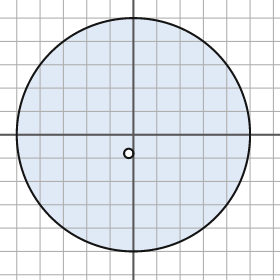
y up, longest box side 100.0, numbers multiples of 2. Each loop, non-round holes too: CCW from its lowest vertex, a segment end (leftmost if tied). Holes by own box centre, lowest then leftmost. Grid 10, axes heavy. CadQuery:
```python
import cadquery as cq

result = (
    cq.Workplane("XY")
    .moveTo(0.0, 0.0)
    .circle(50.0)
    .moveTo(-2.0, -8.0)
    .circle(2.0)
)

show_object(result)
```